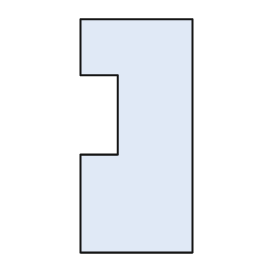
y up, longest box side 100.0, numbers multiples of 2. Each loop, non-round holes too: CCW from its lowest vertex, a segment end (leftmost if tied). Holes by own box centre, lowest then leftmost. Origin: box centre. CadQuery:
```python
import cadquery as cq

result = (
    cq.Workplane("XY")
    .moveTo(-24.0, -50.0)
    .lineTo(24.0, -50.0)
    .lineTo(24.0, 50.0)
    .lineTo(-24.0, 50.0)
    .lineTo(-24.0, 26.0)
    .lineTo(-8.0, 26.0)
    .lineTo(-8.0, -8.0)
    .lineTo(-24.0, -8.0)
    .close()
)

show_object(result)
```